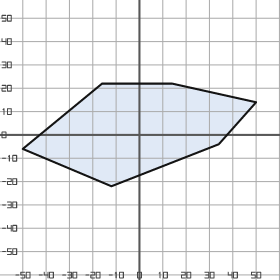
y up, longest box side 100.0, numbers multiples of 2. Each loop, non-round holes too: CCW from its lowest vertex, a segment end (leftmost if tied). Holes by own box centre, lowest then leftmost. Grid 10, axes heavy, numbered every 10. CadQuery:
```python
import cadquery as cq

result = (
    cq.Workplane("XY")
    .moveTo(-12.0, -22.0)
    .lineTo(34.0, -4.0)
    .lineTo(50.0, 14.0)
    .lineTo(14.0, 22.0)
    .lineTo(-16.0, 22.0)
    .lineTo(-50.0, -6.0)
    .close()
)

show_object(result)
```